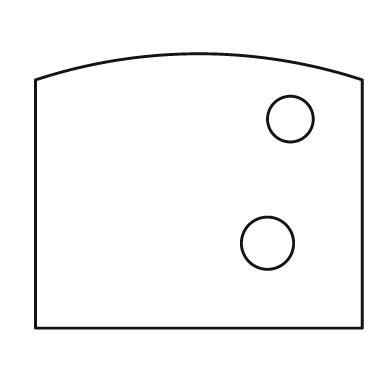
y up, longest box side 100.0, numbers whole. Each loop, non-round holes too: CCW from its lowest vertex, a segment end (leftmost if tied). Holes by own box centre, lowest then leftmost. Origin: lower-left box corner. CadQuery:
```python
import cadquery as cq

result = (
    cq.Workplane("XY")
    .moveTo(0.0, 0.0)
    .lineTo(100.0, 0.0)
    .lineTo(100.0, 76.0)
    .threePointArc((50.0, 84.0), (0.0, 76.0))
    .close()
    .moveTo(71.0, 26.0)
    .circle(8.0)
    .moveTo(78.0, 64.0)
    .circle(7.0)
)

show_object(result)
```